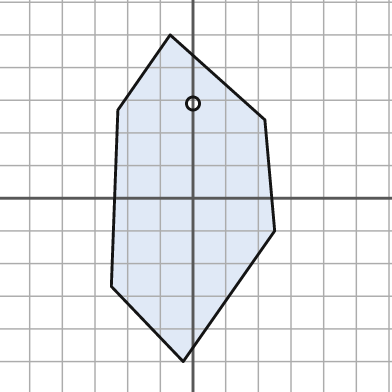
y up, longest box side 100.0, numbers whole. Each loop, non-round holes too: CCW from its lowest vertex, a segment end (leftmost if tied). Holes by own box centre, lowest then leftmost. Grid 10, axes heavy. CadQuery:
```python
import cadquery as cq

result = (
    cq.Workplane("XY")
    .moveTo(-3.0, -50.0)
    .lineTo(25.0, -10.0)
    .lineTo(22.0, 24.0)
    .lineTo(-7.0, 50.0)
    .lineTo(-23.0, 27.0)
    .lineTo(-25.0, -27.0)
    .close()
    .moveTo(0.0, 29.0)
    .circle(2.0)
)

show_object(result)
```